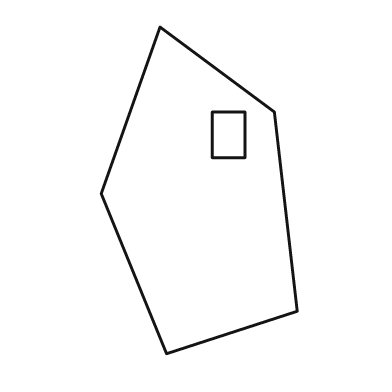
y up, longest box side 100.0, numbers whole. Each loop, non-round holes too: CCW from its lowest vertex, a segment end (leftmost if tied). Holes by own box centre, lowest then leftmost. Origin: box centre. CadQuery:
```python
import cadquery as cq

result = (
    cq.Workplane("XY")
    .moveTo(-10.0, -50.0)
    .lineTo(30.0, -37.0)
    .lineTo(23.0, 24.0)
    .lineTo(-12.0, 50.0)
    .lineTo(-30.0, -1.0)
    .close()
    .moveTo(4.0, 10.0)
    .lineTo(14.0, 10.0)
    .lineTo(14.0, 24.0)
    .lineTo(4.0, 24.0)
    .close()
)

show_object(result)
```